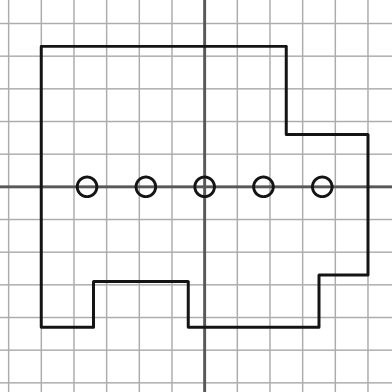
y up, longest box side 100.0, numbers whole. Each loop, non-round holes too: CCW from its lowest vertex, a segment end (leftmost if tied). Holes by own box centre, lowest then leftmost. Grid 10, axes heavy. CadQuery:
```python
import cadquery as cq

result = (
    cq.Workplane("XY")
    .moveTo(-50.0, -43.0)
    .lineTo(-34.0, -43.0)
    .lineTo(-34.0, -29.0)
    .lineTo(-5.0, -29.0)
    .lineTo(-5.0, -43.0)
    .lineTo(35.0, -43.0)
    .lineTo(35.0, -27.0)
    .lineTo(50.0, -27.0)
    .lineTo(50.0, 16.0)
    .lineTo(25.0, 16.0)
    .lineTo(25.0, 43.0)
    .lineTo(-50.0, 43.0)
    .close()
    .moveTo(-36.0, 0.0)
    .circle(3.0)
    .moveTo(-18.0, 0.0)
    .circle(3.0)
    .moveTo(0.0, 0.0)
    .circle(3.0)
    .moveTo(18.0, 0.0)
    .circle(3.0)
    .moveTo(36.0, 0.0)
    .circle(3.0)
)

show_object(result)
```